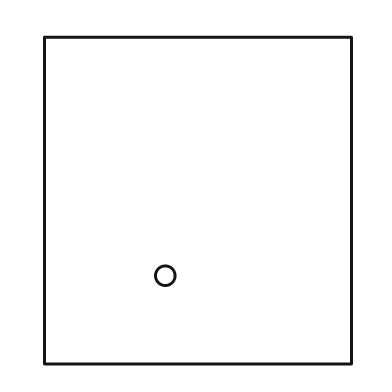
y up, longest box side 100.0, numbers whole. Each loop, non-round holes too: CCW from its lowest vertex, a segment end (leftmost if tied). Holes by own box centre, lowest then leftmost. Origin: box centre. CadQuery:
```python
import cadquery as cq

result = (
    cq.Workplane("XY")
    .moveTo(-47.0, -50.0)
    .lineTo(47.0, -50.0)
    .lineTo(47.0, 50.0)
    .lineTo(-47.0, 50.0)
    .close()
    .moveTo(-10.0, -23.0)
    .circle(3.0)
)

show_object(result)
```